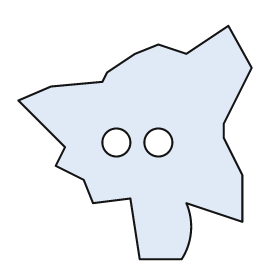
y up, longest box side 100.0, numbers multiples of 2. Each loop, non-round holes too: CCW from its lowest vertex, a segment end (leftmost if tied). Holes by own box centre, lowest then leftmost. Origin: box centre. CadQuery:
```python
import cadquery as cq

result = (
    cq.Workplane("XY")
    .moveTo(2.0, -50.0)
    .lineTo(20.0, -50.0)
    .threePointArc((24.0, -38.0), (22.0, -26.0))
    .lineTo(46.0, -34.0)
    .lineTo(46.0, -14.0)
    .lineTo(38.0, 2.0)
    .lineTo(38.0, 8.0)
    .lineTo(50.0, 32.0)
    .lineTo(40.0, 50.0)
    .lineTo(22.0, 38.0)
    .lineTo(10.0, 42.0)
    .lineTo(0.0, 38.0)
    .lineTo(-12.0, 30.0)
    .lineTo(-14.0, 26.0)
    .lineTo(-36.0, 24.0)
    .lineTo(-50.0, 18.0)
    .lineTo(-30.0, -2.0)
    .lineTo(-34.0, -10.0)
    .lineTo(-22.0, -16.0)
    .lineTo(-18.0, -26.0)
    .lineTo(-2.0, -24.0)
    .close()
    .moveTo(-8.0, 0.0)
    .circle(6.0)
    .moveTo(10.0, 0.0)
    .circle(6.0)
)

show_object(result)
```